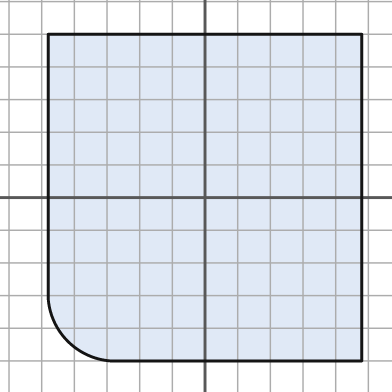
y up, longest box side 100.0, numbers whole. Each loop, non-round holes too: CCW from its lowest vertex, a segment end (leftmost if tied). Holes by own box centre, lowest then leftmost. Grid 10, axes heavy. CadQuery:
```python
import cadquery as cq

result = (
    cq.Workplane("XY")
    .moveTo(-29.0, -50.0)
    .lineTo(48.0, -50.0)
    .lineTo(48.0, 50.0)
    .lineTo(-48.0, 50.0)
    .lineTo(-48.0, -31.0)
    .threePointArc((-42.0, -44.0), (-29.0, -50.0))
    .close()
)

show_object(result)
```